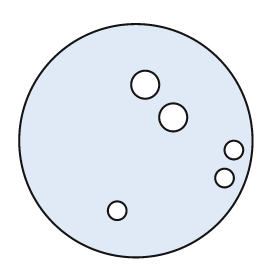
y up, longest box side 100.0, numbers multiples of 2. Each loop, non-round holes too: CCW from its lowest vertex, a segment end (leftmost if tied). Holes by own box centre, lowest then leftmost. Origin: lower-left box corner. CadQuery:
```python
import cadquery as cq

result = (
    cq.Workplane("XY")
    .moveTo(50.0, 50.0)
    .circle(50.0)
    .moveTo(42.0, 20.0)
    .circle(4.0)
    .moveTo(88.0, 34.0)
    .circle(4.0)
    .moveTo(92.0, 46.0)
    .circle(4.0)
    .moveTo(66.0, 60.0)
    .circle(6.0)
    .moveTo(54.0, 74.0)
    .circle(6.0)
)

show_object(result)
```